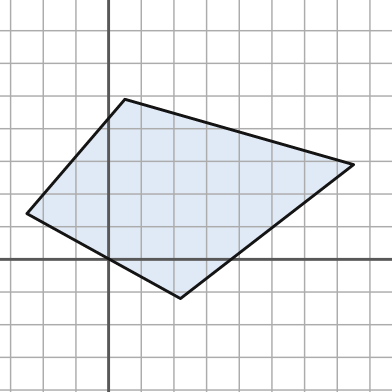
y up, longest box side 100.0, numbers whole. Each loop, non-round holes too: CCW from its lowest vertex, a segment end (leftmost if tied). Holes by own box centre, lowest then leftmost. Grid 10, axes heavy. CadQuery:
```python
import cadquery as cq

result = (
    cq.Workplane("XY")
    .moveTo(22.0, -12.0)
    .lineTo(75.0, 29.0)
    .lineTo(5.0, 49.0)
    .lineTo(-25.0, 14.0)
    .close()
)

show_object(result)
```